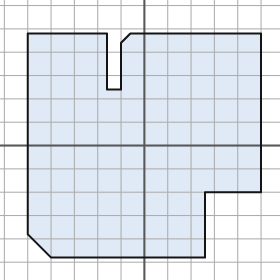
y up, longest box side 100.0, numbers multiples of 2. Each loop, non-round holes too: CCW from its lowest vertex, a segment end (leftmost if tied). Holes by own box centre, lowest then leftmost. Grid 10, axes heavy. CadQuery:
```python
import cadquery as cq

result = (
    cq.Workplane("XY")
    .moveTo(-40.0, -48.0)
    .lineTo(26.0, -48.0)
    .lineTo(26.0, -20.0)
    .lineTo(50.0, -20.0)
    .lineTo(50.0, 48.0)
    .lineTo(-6.0, 48.0)
    .lineTo(-10.0, 44.0)
    .lineTo(-10.0, 24.0)
    .lineTo(-16.0, 24.0)
    .lineTo(-16.0, 48.0)
    .lineTo(-50.0, 48.0)
    .lineTo(-50.0, -38.0)
    .close()
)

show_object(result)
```